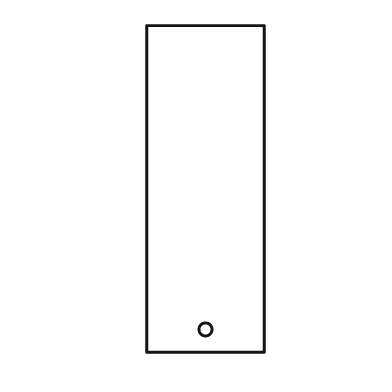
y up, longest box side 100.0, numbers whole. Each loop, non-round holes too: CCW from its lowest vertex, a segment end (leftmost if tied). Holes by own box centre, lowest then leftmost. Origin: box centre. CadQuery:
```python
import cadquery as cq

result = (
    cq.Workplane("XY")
    .moveTo(-18.0, -50.0)
    .lineTo(18.0, -50.0)
    .lineTo(18.0, 50.0)
    .lineTo(-18.0, 50.0)
    .close()
    .moveTo(0.0, -43.0)
    .circle(2.0)
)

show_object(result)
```